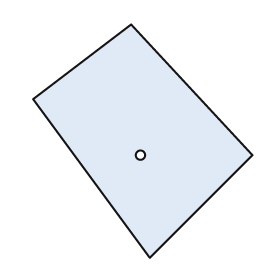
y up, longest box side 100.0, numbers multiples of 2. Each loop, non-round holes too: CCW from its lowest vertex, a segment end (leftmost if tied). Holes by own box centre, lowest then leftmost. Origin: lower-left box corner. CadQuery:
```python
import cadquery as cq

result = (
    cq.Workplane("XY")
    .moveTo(50.0, 0.0)
    .lineTo(94.0, 44.0)
    .lineTo(42.0, 100.0)
    .lineTo(0.0, 68.0)
    .close()
    .moveTo(46.0, 44.0)
    .circle(2.0)
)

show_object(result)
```